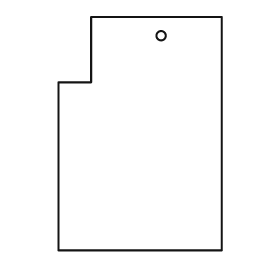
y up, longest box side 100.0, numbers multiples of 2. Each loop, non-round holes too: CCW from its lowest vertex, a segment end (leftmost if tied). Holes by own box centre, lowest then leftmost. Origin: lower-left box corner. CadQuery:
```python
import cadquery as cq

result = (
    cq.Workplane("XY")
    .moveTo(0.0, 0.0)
    .lineTo(70.0, 0.0)
    .lineTo(70.0, 100.0)
    .lineTo(14.0, 100.0)
    .lineTo(14.0, 72.0)
    .lineTo(0.0, 72.0)
    .close()
    .moveTo(44.0, 92.0)
    .circle(2.0)
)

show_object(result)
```